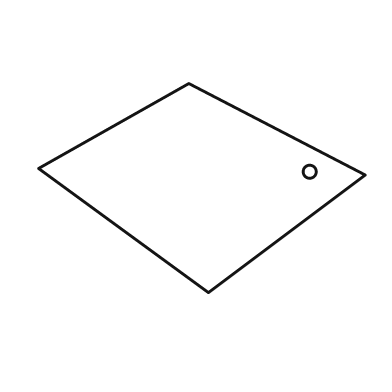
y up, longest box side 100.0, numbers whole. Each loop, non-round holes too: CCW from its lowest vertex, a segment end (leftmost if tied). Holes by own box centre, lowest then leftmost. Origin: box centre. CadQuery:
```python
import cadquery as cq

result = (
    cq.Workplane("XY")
    .moveTo(2.0, -32.0)
    .lineTo(50.0, 4.0)
    .lineTo(-4.0, 32.0)
    .lineTo(-50.0, 6.0)
    .close()
    .moveTo(33.0, 5.0)
    .circle(2.0)
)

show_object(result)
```